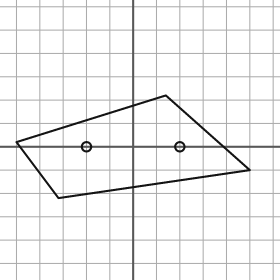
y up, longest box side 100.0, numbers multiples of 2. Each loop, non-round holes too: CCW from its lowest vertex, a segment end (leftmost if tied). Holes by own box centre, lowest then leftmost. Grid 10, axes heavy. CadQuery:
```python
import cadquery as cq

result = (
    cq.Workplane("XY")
    .moveTo(-32.0, -22.0)
    .lineTo(50.0, -10.0)
    .lineTo(14.0, 22.0)
    .lineTo(-50.0, 2.0)
    .close()
    .moveTo(-20.0, 0.0)
    .circle(2.0)
    .moveTo(20.0, 0.0)
    .circle(2.0)
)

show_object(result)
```